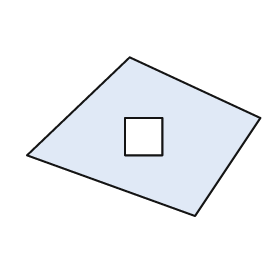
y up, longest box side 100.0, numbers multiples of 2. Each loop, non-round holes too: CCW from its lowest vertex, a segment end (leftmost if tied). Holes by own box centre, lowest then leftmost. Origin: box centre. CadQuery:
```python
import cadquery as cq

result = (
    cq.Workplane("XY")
    .moveTo(22.0, -34.0)
    .lineTo(50.0, 8.0)
    .lineTo(-6.0, 34.0)
    .lineTo(-50.0, -8.0)
    .close()
    .moveTo(-8.0, -8.0)
    .lineTo(8.0, -8.0)
    .lineTo(8.0, 8.0)
    .lineTo(-8.0, 8.0)
    .close()
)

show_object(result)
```